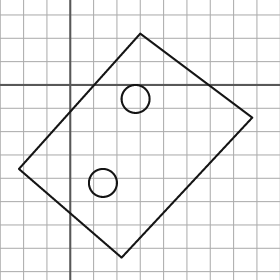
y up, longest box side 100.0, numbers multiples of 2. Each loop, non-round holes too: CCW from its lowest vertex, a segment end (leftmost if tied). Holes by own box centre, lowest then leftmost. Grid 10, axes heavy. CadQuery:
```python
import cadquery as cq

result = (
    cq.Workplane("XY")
    .moveTo(22.0, -74.0)
    .lineTo(78.0, -14.0)
    .lineTo(30.0, 22.0)
    .lineTo(-22.0, -36.0)
    .close()
    .moveTo(14.0, -42.0)
    .circle(6.0)
    .moveTo(28.0, -6.0)
    .circle(6.0)
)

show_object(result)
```